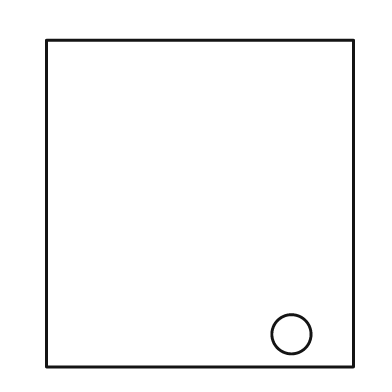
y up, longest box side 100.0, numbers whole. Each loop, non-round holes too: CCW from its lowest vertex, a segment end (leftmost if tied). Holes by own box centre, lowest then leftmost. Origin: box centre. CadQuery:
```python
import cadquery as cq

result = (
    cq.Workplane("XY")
    .moveTo(-47.0, -50.0)
    .lineTo(47.0, -50.0)
    .lineTo(47.0, 50.0)
    .lineTo(-47.0, 50.0)
    .close()
    .moveTo(28.0, -40.0)
    .circle(6.0)
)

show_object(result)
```